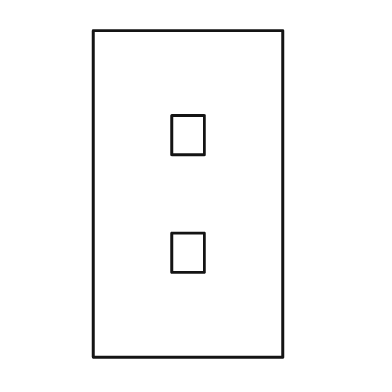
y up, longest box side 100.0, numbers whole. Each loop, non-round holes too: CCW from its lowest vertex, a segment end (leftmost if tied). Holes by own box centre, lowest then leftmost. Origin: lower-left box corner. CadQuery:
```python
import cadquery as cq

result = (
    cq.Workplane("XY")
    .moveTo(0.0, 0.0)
    .lineTo(58.0, 0.0)
    .lineTo(58.0, 100.0)
    .lineTo(0.0, 100.0)
    .close()
    .moveTo(24.0, 26.0)
    .lineTo(34.0, 26.0)
    .lineTo(34.0, 38.0)
    .lineTo(24.0, 38.0)
    .close()
    .moveTo(24.0, 62.0)
    .lineTo(34.0, 62.0)
    .lineTo(34.0, 74.0)
    .lineTo(24.0, 74.0)
    .close()
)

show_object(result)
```